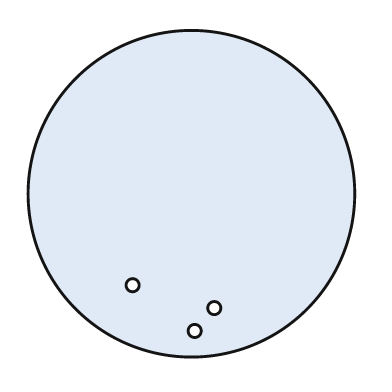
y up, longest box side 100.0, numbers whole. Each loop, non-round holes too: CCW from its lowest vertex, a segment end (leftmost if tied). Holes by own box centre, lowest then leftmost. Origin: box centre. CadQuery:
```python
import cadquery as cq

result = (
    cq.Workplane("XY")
    .moveTo(0.0, 0.0)
    .circle(50.0)
    .moveTo(1.0, -42.0)
    .circle(2.0)
    .moveTo(7.0, -35.0)
    .circle(2.0)
    .moveTo(-18.0, -28.0)
    .circle(2.0)
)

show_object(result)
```